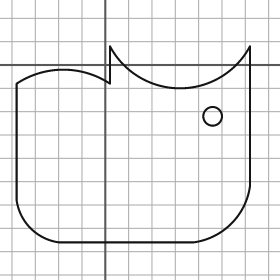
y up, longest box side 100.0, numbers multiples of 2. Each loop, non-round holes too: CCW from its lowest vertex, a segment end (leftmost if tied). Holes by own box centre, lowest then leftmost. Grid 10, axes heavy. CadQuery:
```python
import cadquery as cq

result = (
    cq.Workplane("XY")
    .moveTo(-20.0, -76.0)
    .lineTo(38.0, -76.0)
    .threePointArc((54.0, -68.0), (62.0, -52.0))
    .lineTo(62.0, 8.0)
    .threePointArc((32.0, -10.0), (2.0, 8.0))
    .lineTo(2.0, -8.0)
    .threePointArc((-18.0, -2.0), (-38.0, -8.0))
    .lineTo(-38.0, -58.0)
    .threePointArc((-32.0, -70.0), (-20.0, -76.0))
    .close()
    .moveTo(46.0, -22.0)
    .circle(4.0)
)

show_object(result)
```